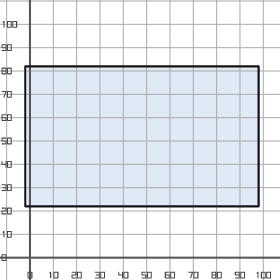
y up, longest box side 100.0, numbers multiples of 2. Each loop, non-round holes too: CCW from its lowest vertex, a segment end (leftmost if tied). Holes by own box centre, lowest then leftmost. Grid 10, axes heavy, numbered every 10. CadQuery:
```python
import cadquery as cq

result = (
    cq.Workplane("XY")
    .moveTo(-2.0, 22.0)
    .lineTo(98.0, 22.0)
    .lineTo(98.0, 82.0)
    .lineTo(-2.0, 82.0)
    .close()
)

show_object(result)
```